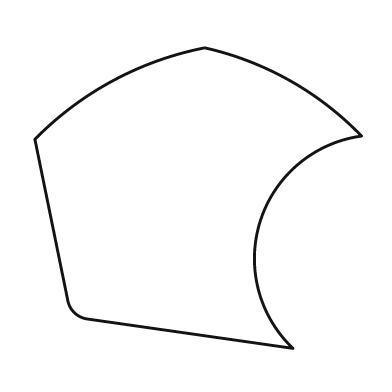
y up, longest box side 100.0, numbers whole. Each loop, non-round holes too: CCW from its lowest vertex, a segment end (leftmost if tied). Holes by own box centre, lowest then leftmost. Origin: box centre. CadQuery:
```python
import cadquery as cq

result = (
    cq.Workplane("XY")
    .moveTo(29.0, -46.0)
    .threePointArc((19.0, -7.0), (50.0, 19.0))
    .threePointArc((28.0, 36.0), (2.0, 46.0))
    .threePointArc((-26.0, 36.0), (-50.0, 18.0))
    .lineTo(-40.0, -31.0)
    .threePointArc((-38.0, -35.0), (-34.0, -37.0))
    .close()
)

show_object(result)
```